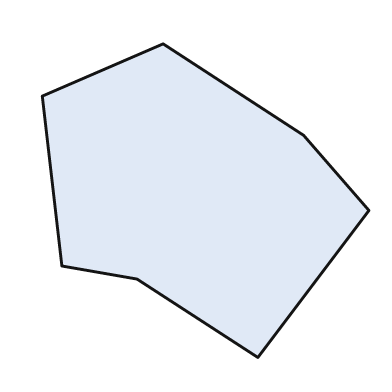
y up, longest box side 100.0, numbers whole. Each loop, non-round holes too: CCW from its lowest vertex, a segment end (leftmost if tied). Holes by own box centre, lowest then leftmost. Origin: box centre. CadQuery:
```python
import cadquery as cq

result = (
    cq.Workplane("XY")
    .moveTo(16.0, -48.0)
    .lineTo(50.0, -3.0)
    .lineTo(30.0, 20.0)
    .lineTo(-13.0, 48.0)
    .lineTo(-50.0, 32.0)
    .lineTo(-44.0, -20.0)
    .lineTo(-21.0, -24.0)
    .close()
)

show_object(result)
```